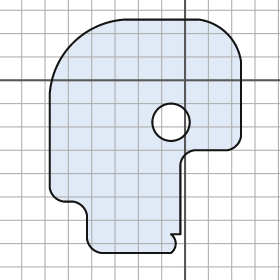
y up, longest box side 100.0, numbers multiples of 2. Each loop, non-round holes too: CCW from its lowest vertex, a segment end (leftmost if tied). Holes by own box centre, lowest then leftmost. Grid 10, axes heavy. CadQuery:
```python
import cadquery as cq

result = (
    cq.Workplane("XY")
    .moveTo(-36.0, -74.0)
    .lineTo(-6.0, -74.0)
    .threePointArc((-4.0, -70.0), (-6.0, -66.0))
    .lineTo(-2.0, -66.0)
    .lineTo(-2.0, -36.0)
    .threePointArc((0.0, -32.0), (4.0, -30.0))
    .lineTo(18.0, -30.0)
    .threePointArc((22.0, -28.0), (24.0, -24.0))
    .lineTo(24.0, 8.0)
    .threePointArc((18.0, 20.0), (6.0, 26.0))
    .lineTo(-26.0, 26.0)
    .threePointArc((-48.0, 16.0), (-58.0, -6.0))
    .lineTo(-58.0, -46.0)
    .threePointArc((-56.0, -50.0), (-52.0, -52.0))
    .lineTo(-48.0, -52.0)
    .threePointArc((-44.0, -54.0), (-42.0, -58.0))
    .lineTo(-42.0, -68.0)
    .threePointArc((-40.0, -72.0), (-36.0, -74.0))
    .close()
    .moveTo(-6.0, -18.0)
    .circle(8.0)
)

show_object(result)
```